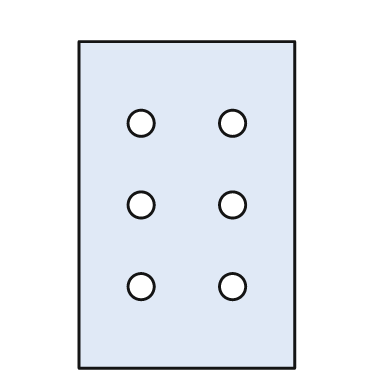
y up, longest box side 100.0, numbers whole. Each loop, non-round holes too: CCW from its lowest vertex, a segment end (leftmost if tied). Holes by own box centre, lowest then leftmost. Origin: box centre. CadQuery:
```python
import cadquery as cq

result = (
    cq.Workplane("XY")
    .moveTo(-33.0, -50.0)
    .lineTo(33.0, -50.0)
    .lineTo(33.0, 50.0)
    .lineTo(-33.0, 50.0)
    .close()
    .moveTo(-14.0, -25.0)
    .circle(4.0)
    .moveTo(14.0, -25.0)
    .circle(4.0)
    .moveTo(-14.0, 0.0)
    .circle(4.0)
    .moveTo(14.0, 0.0)
    .circle(4.0)
    .moveTo(-14.0, 25.0)
    .circle(4.0)
    .moveTo(14.0, 25.0)
    .circle(4.0)
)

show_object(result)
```